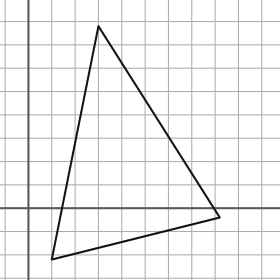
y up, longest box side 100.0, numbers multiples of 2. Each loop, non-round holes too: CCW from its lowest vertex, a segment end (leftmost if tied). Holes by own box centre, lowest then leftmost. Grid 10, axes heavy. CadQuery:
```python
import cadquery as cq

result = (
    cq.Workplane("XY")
    .moveTo(10.0, -22.0)
    .lineTo(82.0, -4.0)
    .lineTo(30.0, 78.0)
    .close()
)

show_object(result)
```